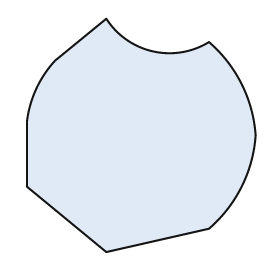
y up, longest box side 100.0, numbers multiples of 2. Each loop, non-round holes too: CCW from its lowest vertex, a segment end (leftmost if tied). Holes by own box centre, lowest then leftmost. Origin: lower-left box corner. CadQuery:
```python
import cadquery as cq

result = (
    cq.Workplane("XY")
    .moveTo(34.0, 0.0)
    .lineTo(78.0, 10.0)
    .threePointArc((92.0, 28.0), (98.0, 50.0))
    .threePointArc((92.0, 72.0), (78.0, 90.0))
    .threePointArc((54.0, 86.0), (34.0, 100.0))
    .lineTo(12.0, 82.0)
    .threePointArc((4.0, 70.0), (0.0, 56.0))
    .lineTo(0.0, 28.0)
    .close()
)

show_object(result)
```